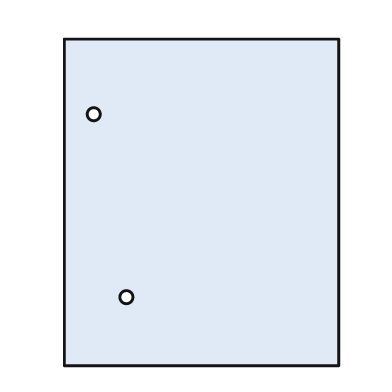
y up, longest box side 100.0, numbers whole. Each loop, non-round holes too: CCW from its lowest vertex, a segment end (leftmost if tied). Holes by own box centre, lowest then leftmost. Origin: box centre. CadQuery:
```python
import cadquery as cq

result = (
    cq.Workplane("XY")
    .moveTo(-42.0, -50.0)
    .lineTo(42.0, -50.0)
    .lineTo(42.0, 50.0)
    .lineTo(-42.0, 50.0)
    .close()
    .moveTo(-23.0, -29.0)
    .circle(2.0)
    .moveTo(-33.0, 27.0)
    .circle(2.0)
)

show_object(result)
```